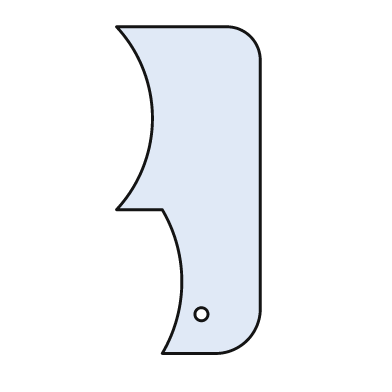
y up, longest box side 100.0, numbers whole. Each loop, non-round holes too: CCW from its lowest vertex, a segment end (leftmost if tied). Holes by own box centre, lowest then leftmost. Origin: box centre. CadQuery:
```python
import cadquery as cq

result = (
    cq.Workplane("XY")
    .moveTo(-8.0, -50.0)
    .lineTo(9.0, -50.0)
    .threePointArc((18.0, -46.0), (22.0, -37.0))
    .lineTo(22.0, 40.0)
    .threePointArc((19.0, 47.0), (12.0, 50.0))
    .lineTo(-22.0, 50.0)
    .threePointArc((-11.0, 22.0), (-22.0, -6.0))
    .lineTo(-8.0, -6.0)
    .threePointArc((-2.0, -28.0), (-8.0, -50.0))
    .close()
    .moveTo(4.0, -38.0)
    .circle(2.0)
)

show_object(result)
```